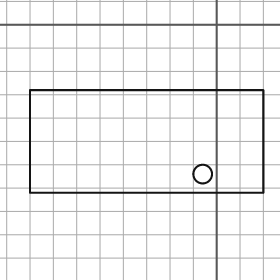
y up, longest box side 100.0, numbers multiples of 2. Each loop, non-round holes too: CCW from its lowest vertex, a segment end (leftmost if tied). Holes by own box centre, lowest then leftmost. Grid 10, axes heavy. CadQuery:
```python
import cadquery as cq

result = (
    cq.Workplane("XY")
    .moveTo(-80.0, -72.0)
    .lineTo(20.0, -72.0)
    .lineTo(20.0, -28.0)
    .lineTo(-80.0, -28.0)
    .close()
    .moveTo(-6.0, -64.0)
    .circle(4.0)
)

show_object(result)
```